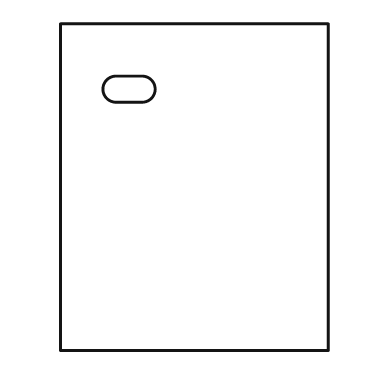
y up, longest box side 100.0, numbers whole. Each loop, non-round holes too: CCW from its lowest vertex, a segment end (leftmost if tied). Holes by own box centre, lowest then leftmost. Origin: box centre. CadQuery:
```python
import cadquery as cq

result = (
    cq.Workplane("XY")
    .moveTo(-41.0, -50.0)
    .lineTo(41.0, -50.0)
    .lineTo(41.0, 50.0)
    .lineTo(-41.0, 50.0)
    .close()
    .moveTo(-24.0, 26.0)
    .lineTo(-16.0, 26.0)
    .threePointArc((-12.0, 30.0), (-16.0, 34.0))
    .lineTo(-24.0, 34.0)
    .threePointArc((-28.0, 30.0), (-24.0, 26.0))
    .close()
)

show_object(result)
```